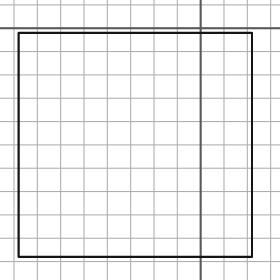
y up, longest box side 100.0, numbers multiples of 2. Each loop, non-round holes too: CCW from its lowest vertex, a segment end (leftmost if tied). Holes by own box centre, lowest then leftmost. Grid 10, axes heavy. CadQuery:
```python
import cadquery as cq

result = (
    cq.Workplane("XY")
    .moveTo(-78.0, -98.0)
    .lineTo(22.0, -98.0)
    .lineTo(22.0, -2.0)
    .lineTo(-78.0, -2.0)
    .close()
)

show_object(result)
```